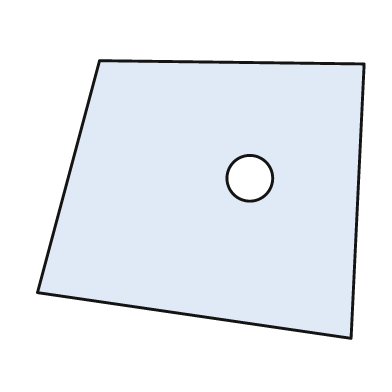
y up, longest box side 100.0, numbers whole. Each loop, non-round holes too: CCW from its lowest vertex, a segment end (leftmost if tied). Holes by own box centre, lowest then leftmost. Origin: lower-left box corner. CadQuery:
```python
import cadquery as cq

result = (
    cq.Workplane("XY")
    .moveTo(96.0, 0.0)
    .lineTo(100.0, 84.0)
    .lineTo(19.0, 85.0)
    .lineTo(0.0, 14.0)
    .close()
    .moveTo(65.0, 49.0)
    .circle(7.0)
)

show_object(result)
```